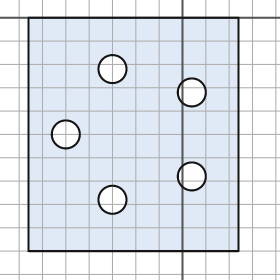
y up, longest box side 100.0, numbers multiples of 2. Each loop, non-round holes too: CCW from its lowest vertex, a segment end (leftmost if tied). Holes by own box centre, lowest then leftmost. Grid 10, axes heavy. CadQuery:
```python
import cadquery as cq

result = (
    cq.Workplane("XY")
    .moveTo(-66.0, -100.0)
    .lineTo(24.0, -100.0)
    .lineTo(24.0, 0.0)
    .lineTo(-66.0, 0.0)
    .close()
    .moveTo(-30.0, -78.0)
    .circle(6.0)
    .moveTo(4.0, -68.0)
    .circle(6.0)
    .moveTo(-50.0, -50.0)
    .circle(6.0)
    .moveTo(4.0, -32.0)
    .circle(6.0)
    .moveTo(-30.0, -22.0)
    .circle(6.0)
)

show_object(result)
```